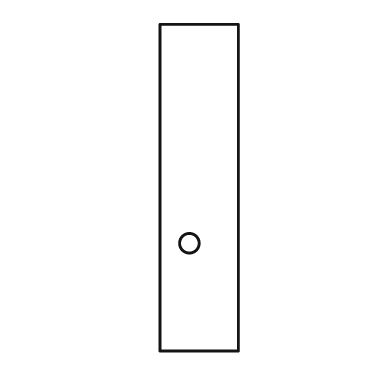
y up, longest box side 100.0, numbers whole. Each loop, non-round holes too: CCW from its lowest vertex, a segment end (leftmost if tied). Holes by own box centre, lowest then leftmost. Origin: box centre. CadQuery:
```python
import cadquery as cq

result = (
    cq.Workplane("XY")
    .moveTo(-12.0, -50.0)
    .lineTo(12.0, -50.0)
    .lineTo(12.0, 50.0)
    .lineTo(-12.0, 50.0)
    .close()
    .moveTo(-3.0, -17.0)
    .circle(3.0)
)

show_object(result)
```